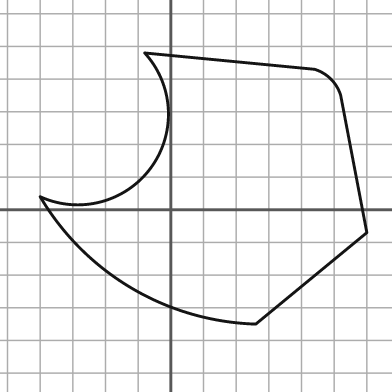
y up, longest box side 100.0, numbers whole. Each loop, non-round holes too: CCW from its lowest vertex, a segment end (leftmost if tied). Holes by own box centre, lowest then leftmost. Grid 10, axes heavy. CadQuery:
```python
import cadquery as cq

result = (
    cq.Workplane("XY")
    .moveTo(26.0, -35.0)
    .lineTo(60.0, -7.0)
    .lineTo(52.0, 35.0)
    .threePointArc((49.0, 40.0), (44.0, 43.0))
    .lineTo(-8.0, 48.0)
    .threePointArc((-6.0, 13.0), (-40.0, 4.0))
    .threePointArc((-12.0, -24.0), (26.0, -35.0))
    .close()
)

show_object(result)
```